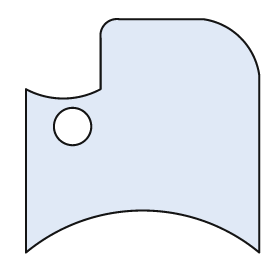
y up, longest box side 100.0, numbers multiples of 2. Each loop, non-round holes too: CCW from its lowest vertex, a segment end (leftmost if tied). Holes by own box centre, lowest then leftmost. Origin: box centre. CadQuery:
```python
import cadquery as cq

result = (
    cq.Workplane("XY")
    .moveTo(-50.0, -50.0)
    .threePointArc((0.0, -32.0), (50.0, -50.0))
    .lineTo(50.0, 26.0)
    .threePointArc((42.0, 42.0), (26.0, 50.0))
    .lineTo(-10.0, 50.0)
    .threePointArc((-16.0, 48.0), (-18.0, 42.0))
    .lineTo(-18.0, 20.0)
    .threePointArc((-34.0, 16.0), (-50.0, 20.0))
    .close()
    .moveTo(-30.0, 4.0)
    .circle(8.0)
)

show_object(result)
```